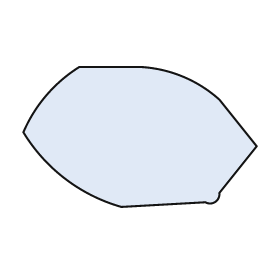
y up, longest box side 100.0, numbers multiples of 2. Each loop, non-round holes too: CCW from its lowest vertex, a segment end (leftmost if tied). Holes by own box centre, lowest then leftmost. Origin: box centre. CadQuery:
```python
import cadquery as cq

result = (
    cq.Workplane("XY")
    .moveTo(-8.0, -30.0)
    .lineTo(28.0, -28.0)
    .threePointArc((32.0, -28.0), (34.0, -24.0))
    .lineTo(50.0, -4.0)
    .lineTo(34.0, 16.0)
    .threePointArc((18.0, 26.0), (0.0, 30.0))
    .lineTo(-26.0, 30.0)
    .threePointArc((-40.0, 18.0), (-50.0, 2.0))
    .threePointArc((-32.0, -18.0), (-8.0, -30.0))
    .close()
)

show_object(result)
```